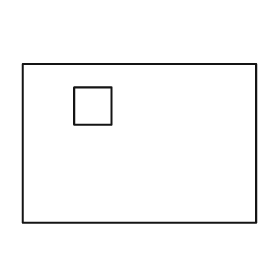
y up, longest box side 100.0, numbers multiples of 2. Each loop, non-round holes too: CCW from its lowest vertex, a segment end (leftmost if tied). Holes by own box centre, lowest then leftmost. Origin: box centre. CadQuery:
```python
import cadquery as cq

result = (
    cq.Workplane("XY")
    .moveTo(-50.0, -34.0)
    .lineTo(50.0, -34.0)
    .lineTo(50.0, 34.0)
    .lineTo(-50.0, 34.0)
    .close()
    .moveTo(-28.0, 8.0)
    .lineTo(-12.0, 8.0)
    .lineTo(-12.0, 24.0)
    .lineTo(-28.0, 24.0)
    .close()
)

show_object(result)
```